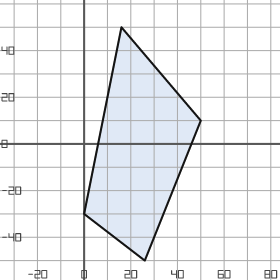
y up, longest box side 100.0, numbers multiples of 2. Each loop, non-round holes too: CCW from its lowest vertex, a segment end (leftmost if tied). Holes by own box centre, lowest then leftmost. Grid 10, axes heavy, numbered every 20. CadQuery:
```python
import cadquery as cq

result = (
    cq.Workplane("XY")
    .moveTo(26.0, -50.0)
    .lineTo(50.0, 10.0)
    .lineTo(16.0, 50.0)
    .lineTo(0.0, -30.0)
    .close()
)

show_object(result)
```